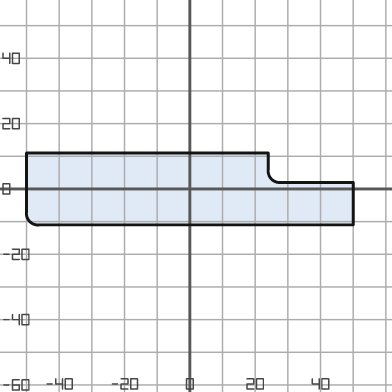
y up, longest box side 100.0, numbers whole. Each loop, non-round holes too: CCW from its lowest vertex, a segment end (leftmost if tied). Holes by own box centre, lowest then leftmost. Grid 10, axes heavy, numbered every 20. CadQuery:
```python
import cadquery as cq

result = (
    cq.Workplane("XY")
    .moveTo(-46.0, -11.0)
    .lineTo(50.0, -11.0)
    .lineTo(50.0, 2.0)
    .lineTo(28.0, 2.0)
    .threePointArc((25.0, 3.0), (24.0, 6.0))
    .lineTo(24.0, 11.0)
    .lineTo(-50.0, 11.0)
    .lineTo(-50.0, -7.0)
    .threePointArc((-49.0, -10.0), (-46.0, -11.0))
    .close()
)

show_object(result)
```